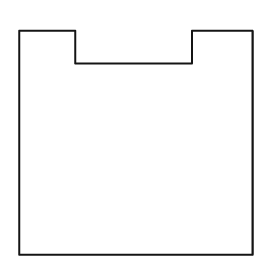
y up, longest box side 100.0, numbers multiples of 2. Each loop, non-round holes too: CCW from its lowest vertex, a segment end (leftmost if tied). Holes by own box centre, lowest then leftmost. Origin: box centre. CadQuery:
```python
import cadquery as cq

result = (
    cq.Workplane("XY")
    .moveTo(-50.0, -48.0)
    .lineTo(50.0, -48.0)
    .lineTo(50.0, 48.0)
    .lineTo(24.0, 48.0)
    .lineTo(24.0, 34.0)
    .lineTo(-26.0, 34.0)
    .lineTo(-26.0, 48.0)
    .lineTo(-50.0, 48.0)
    .close()
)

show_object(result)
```